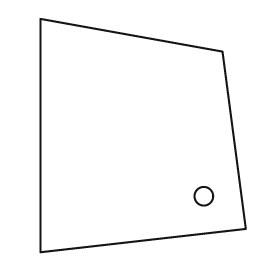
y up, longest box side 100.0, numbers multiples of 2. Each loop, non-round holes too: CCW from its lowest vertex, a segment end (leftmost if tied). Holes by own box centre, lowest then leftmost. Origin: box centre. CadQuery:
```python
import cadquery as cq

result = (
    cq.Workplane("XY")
    .moveTo(-44.0, -50.0)
    .lineTo(44.0, -40.0)
    .lineTo(34.0, 36.0)
    .lineTo(-44.0, 50.0)
    .close()
    .moveTo(26.0, -26.0)
    .circle(4.0)
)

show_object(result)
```